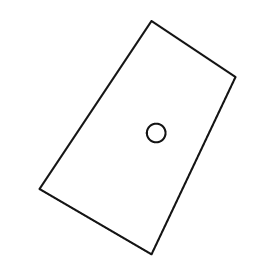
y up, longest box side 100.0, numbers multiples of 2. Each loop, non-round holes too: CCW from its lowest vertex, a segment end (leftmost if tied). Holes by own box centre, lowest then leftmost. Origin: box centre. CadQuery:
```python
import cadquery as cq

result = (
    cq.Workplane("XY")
    .moveTo(6.0, -50.0)
    .lineTo(42.0, 26.0)
    .lineTo(6.0, 50.0)
    .lineTo(-42.0, -22.0)
    .close()
    .moveTo(8.0, 2.0)
    .circle(4.0)
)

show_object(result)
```